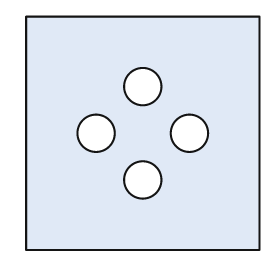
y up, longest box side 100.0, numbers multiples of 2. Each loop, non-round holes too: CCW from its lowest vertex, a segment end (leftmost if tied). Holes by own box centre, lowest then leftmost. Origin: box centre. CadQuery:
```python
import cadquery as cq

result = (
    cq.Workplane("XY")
    .moveTo(-50.0, -50.0)
    .lineTo(50.0, -50.0)
    .lineTo(50.0, 50.0)
    .lineTo(-50.0, 50.0)
    .close()
    .moveTo(0.0, -20.0)
    .circle(8.0)
    .moveTo(-20.0, 0.0)
    .circle(8.0)
    .moveTo(20.0, 0.0)
    .circle(8.0)
    .moveTo(0.0, 20.0)
    .circle(8.0)
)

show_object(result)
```